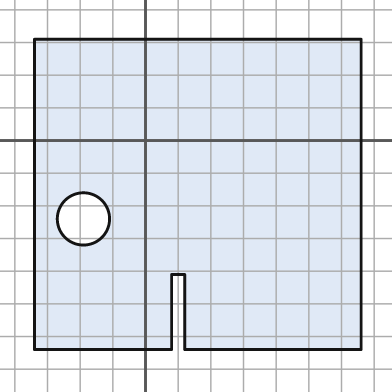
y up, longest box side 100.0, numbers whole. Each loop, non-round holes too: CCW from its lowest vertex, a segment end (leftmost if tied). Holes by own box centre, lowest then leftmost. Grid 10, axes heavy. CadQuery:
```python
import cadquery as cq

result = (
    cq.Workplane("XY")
    .moveTo(-34.0, -64.0)
    .lineTo(8.0, -64.0)
    .lineTo(8.0, -41.0)
    .lineTo(12.0, -41.0)
    .lineTo(12.0, -64.0)
    .lineTo(66.0, -64.0)
    .lineTo(66.0, 31.0)
    .lineTo(-34.0, 31.0)
    .close()
    .moveTo(-19.0, -24.0)
    .circle(8.0)
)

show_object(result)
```